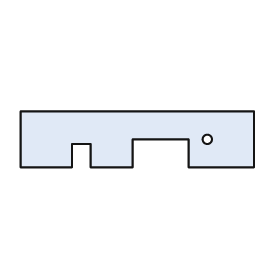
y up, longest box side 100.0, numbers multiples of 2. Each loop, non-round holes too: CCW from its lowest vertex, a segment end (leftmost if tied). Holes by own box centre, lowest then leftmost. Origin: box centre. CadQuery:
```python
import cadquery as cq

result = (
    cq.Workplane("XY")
    .moveTo(-50.0, -12.0)
    .lineTo(-28.0, -12.0)
    .lineTo(-28.0, -2.0)
    .lineTo(-20.0, -2.0)
    .lineTo(-20.0, -12.0)
    .lineTo(-2.0, -12.0)
    .lineTo(-2.0, 0.0)
    .lineTo(22.0, 0.0)
    .lineTo(22.0, -12.0)
    .lineTo(50.0, -12.0)
    .lineTo(50.0, 12.0)
    .lineTo(-50.0, 12.0)
    .close()
    .moveTo(30.0, 0.0)
    .circle(2.0)
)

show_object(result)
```